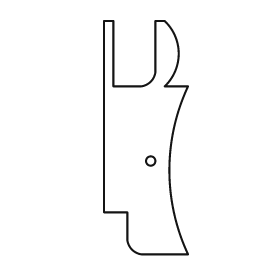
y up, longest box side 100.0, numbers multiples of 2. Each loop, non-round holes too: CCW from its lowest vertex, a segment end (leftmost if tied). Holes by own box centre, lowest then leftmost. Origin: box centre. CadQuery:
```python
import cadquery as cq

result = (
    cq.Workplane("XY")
    .moveTo(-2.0, -50.0)
    .lineTo(18.0, -50.0)
    .threePointArc((10.0, -14.0), (18.0, 22.0))
    .lineTo(8.0, 22.0)
    .threePointArc((14.0, 36.0), (8.0, 50.0))
    .lineTo(4.0, 50.0)
    .lineTo(4.0, 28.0)
    .threePointArc((2.0, 24.0), (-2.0, 22.0))
    .lineTo(-14.0, 22.0)
    .lineTo(-14.0, 50.0)
    .lineTo(-18.0, 50.0)
    .lineTo(-18.0, -32.0)
    .lineTo(-8.0, -32.0)
    .lineTo(-8.0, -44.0)
    .threePointArc((-6.0, -48.0), (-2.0, -50.0))
    .close()
    .moveTo(2.0, -10.0)
    .circle(2.0)
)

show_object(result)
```